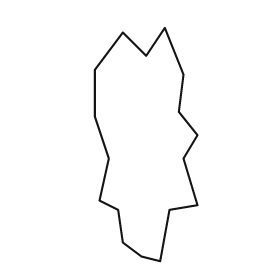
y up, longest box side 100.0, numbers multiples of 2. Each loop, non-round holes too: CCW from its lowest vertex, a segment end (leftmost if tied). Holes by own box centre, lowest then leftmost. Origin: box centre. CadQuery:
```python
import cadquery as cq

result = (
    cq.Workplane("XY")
    .moveTo(6.0, -50.0)
    .lineTo(10.0, -28.0)
    .lineTo(22.0, -26.0)
    .lineTo(16.0, -6.0)
    .lineTo(22.0, 4.0)
    .lineTo(14.0, 14.0)
    .lineTo(16.0, 30.0)
    .lineTo(8.0, 50.0)
    .lineTo(0.0, 38.0)
    .lineTo(-10.0, 48.0)
    .lineTo(-22.0, 32.0)
    .lineTo(-22.0, 12.0)
    .lineTo(-16.0, -6.0)
    .lineTo(-20.0, -24.0)
    .lineTo(-12.0, -28.0)
    .lineTo(-10.0, -42.0)
    .lineTo(-2.0, -48.0)
    .close()
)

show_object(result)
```